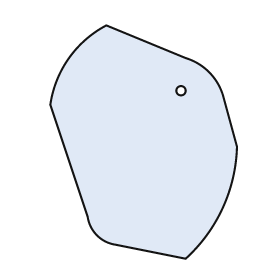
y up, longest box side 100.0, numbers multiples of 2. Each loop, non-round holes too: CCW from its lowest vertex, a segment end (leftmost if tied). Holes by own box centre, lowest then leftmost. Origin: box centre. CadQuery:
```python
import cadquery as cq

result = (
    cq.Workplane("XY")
    .moveTo(18.0, -50.0)
    .threePointArc((34.0, -28.0), (40.0, -2.0))
    .lineTo(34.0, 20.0)
    .threePointArc((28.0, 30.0), (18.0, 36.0))
    .lineTo(-16.0, 50.0)
    .threePointArc((-32.0, 36.0), (-40.0, 16.0))
    .lineTo(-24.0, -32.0)
    .threePointArc((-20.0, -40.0), (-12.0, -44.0))
    .close()
    .moveTo(16.0, 22.0)
    .circle(2.0)
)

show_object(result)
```